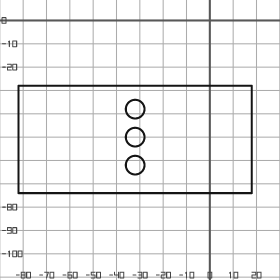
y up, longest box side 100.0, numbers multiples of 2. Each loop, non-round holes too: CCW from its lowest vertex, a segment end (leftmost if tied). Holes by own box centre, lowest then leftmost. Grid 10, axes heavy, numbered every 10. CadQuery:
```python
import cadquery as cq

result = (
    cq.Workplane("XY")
    .moveTo(-82.0, -74.0)
    .lineTo(18.0, -74.0)
    .lineTo(18.0, -28.0)
    .lineTo(-82.0, -28.0)
    .close()
    .moveTo(-32.0, -62.0)
    .circle(4.0)
    .moveTo(-32.0, -50.0)
    .circle(4.0)
    .moveTo(-32.0, -38.0)
    .circle(4.0)
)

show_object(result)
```